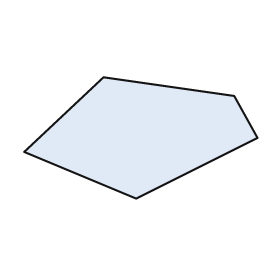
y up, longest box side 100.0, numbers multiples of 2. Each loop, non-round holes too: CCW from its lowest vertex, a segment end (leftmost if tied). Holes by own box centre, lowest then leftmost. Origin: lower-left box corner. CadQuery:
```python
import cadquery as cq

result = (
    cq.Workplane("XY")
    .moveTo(48.0, 0.0)
    .lineTo(100.0, 26.0)
    .lineTo(90.0, 44.0)
    .lineTo(34.0, 52.0)
    .lineTo(0.0, 20.0)
    .close()
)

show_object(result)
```